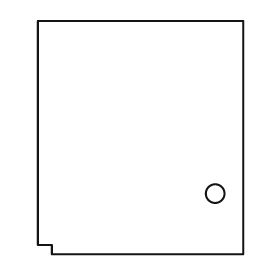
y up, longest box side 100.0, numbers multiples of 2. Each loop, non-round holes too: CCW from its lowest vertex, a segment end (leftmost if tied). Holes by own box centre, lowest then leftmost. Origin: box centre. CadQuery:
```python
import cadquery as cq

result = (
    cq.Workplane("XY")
    .moveTo(-38.0, -50.0)
    .lineTo(44.0, -50.0)
    .lineTo(44.0, 50.0)
    .lineTo(-44.0, 50.0)
    .lineTo(-44.0, -46.0)
    .lineTo(-38.0, -46.0)
    .close()
    .moveTo(32.0, -24.0)
    .circle(4.0)
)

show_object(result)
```